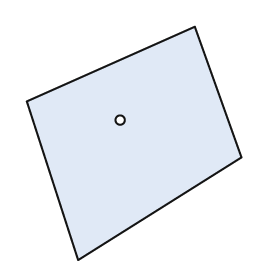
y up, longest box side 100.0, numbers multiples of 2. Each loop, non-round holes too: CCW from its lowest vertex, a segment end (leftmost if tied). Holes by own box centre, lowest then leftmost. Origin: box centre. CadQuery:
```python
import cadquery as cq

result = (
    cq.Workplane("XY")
    .moveTo(-24.0, -50.0)
    .lineTo(46.0, -6.0)
    .lineTo(26.0, 50.0)
    .lineTo(-46.0, 18.0)
    .close()
    .moveTo(-6.0, 10.0)
    .circle(2.0)
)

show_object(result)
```